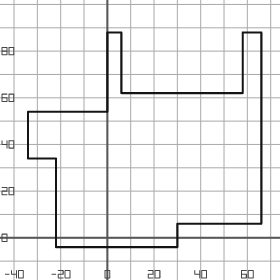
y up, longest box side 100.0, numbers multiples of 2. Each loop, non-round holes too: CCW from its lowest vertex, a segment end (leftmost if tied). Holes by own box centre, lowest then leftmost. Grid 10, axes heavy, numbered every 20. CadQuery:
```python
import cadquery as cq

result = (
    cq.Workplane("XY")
    .moveTo(-22.0, -4.0)
    .lineTo(30.0, -4.0)
    .lineTo(30.0, 6.0)
    .lineTo(66.0, 6.0)
    .lineTo(66.0, 88.0)
    .lineTo(58.0, 88.0)
    .lineTo(58.0, 62.0)
    .lineTo(6.0, 62.0)
    .lineTo(6.0, 88.0)
    .lineTo(0.0, 88.0)
    .lineTo(0.0, 54.0)
    .lineTo(-34.0, 54.0)
    .lineTo(-34.0, 34.0)
    .lineTo(-22.0, 34.0)
    .close()
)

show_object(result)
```